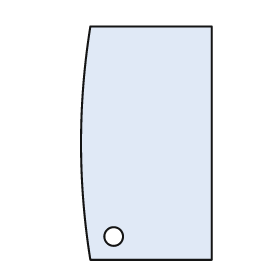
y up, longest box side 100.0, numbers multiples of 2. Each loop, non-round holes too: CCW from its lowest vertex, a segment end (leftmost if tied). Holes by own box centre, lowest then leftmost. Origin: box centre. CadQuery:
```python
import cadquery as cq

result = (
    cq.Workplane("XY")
    .moveTo(-24.0, -50.0)
    .lineTo(28.0, -50.0)
    .lineTo(28.0, 50.0)
    .lineTo(-24.0, 50.0)
    .threePointArc((-28.0, 0.0), (-24.0, -50.0))
    .close()
    .moveTo(-14.0, -40.0)
    .circle(4.0)
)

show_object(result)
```